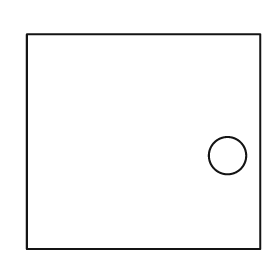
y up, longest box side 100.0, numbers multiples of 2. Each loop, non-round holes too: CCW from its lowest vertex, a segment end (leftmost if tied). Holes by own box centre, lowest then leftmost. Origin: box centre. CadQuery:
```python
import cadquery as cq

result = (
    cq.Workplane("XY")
    .moveTo(-50.0, -46.0)
    .lineTo(50.0, -46.0)
    .lineTo(50.0, 46.0)
    .lineTo(-50.0, 46.0)
    .close()
    .moveTo(36.0, -6.0)
    .circle(8.0)
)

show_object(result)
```